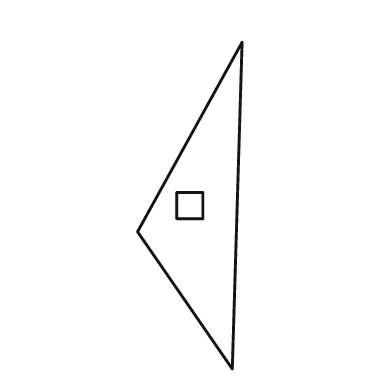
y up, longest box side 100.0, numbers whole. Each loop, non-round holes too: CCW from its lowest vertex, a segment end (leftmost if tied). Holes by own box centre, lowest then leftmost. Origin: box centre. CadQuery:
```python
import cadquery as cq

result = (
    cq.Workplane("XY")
    .moveTo(13.0, -50.0)
    .lineTo(16.0, 50.0)
    .lineTo(-16.0, -8.0)
    .close()
    .moveTo(-4.0, -4.0)
    .lineTo(4.0, -4.0)
    .lineTo(4.0, 4.0)
    .lineTo(-4.0, 4.0)
    .close()
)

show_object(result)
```